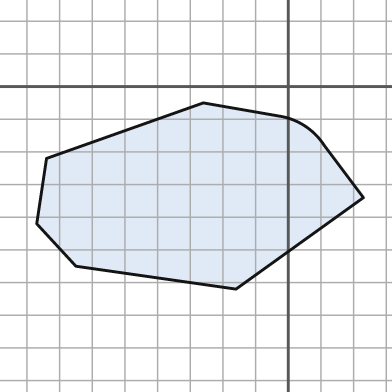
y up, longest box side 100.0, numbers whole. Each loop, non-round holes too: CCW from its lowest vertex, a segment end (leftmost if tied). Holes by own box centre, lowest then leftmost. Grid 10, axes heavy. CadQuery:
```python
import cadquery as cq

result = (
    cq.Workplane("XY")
    .moveTo(-16.0, -62.0)
    .lineTo(23.0, -34.0)
    .lineTo(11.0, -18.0)
    .threePointArc((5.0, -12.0), (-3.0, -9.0))
    .lineTo(-26.0, -5.0)
    .lineTo(-74.0, -22.0)
    .lineTo(-77.0, -42.0)
    .lineTo(-65.0, -55.0)
    .close()
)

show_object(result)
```